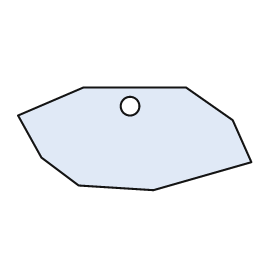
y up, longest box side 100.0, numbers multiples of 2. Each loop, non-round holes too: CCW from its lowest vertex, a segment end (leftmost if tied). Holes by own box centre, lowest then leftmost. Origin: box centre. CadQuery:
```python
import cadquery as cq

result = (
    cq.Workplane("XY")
    .moveTo(8.0, -22.0)
    .lineTo(50.0, -10.0)
    .lineTo(42.0, 8.0)
    .lineTo(22.0, 22.0)
    .lineTo(-22.0, 22.0)
    .lineTo(-50.0, 10.0)
    .lineTo(-40.0, -8.0)
    .lineTo(-24.0, -20.0)
    .close()
    .moveTo(-2.0, 14.0)
    .circle(4.0)
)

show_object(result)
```